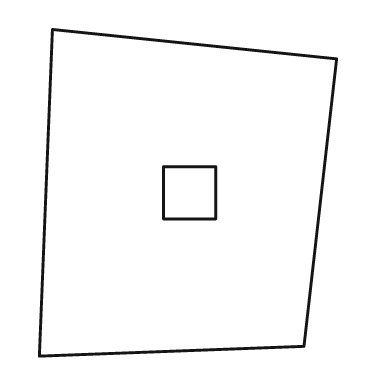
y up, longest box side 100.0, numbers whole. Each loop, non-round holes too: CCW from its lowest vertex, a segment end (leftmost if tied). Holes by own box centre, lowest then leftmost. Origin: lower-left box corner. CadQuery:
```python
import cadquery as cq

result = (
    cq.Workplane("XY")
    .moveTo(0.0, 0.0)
    .lineTo(81.0, 3.0)
    .lineTo(91.0, 91.0)
    .lineTo(4.0, 100.0)
    .close()
    .moveTo(38.0, 42.0)
    .lineTo(54.0, 42.0)
    .lineTo(54.0, 58.0)
    .lineTo(38.0, 58.0)
    .close()
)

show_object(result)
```